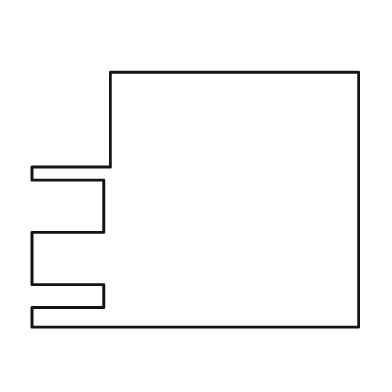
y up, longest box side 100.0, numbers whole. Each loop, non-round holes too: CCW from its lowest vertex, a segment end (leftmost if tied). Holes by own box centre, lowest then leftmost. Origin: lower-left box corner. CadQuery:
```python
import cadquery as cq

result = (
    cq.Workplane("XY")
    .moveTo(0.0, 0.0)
    .lineTo(100.0, 0.0)
    .lineTo(100.0, 78.0)
    .lineTo(24.0, 78.0)
    .lineTo(24.0, 49.0)
    .lineTo(0.0, 49.0)
    .lineTo(0.0, 45.0)
    .lineTo(22.0, 45.0)
    .lineTo(22.0, 29.0)
    .lineTo(0.0, 29.0)
    .lineTo(0.0, 13.0)
    .lineTo(22.0, 13.0)
    .lineTo(22.0, 6.0)
    .lineTo(0.0, 6.0)
    .close()
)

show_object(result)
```